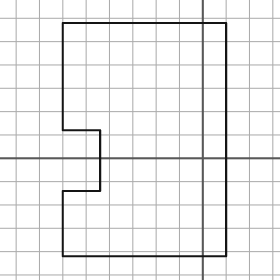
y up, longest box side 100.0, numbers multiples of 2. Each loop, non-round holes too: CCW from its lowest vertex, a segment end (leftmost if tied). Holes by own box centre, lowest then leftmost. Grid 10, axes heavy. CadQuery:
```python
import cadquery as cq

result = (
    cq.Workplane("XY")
    .moveTo(-60.0, -42.0)
    .lineTo(10.0, -42.0)
    .lineTo(10.0, 58.0)
    .lineTo(-60.0, 58.0)
    .lineTo(-60.0, 12.0)
    .lineTo(-44.0, 12.0)
    .lineTo(-44.0, -14.0)
    .lineTo(-60.0, -14.0)
    .close()
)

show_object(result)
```